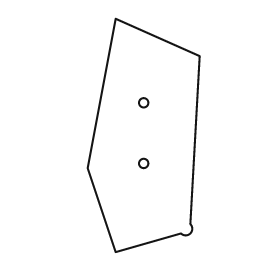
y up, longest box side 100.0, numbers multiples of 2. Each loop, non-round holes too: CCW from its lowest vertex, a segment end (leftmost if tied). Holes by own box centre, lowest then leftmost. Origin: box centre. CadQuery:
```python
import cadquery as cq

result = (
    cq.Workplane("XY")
    .moveTo(-12.0, -50.0)
    .lineTo(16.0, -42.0)
    .threePointArc((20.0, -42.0), (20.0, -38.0))
    .lineTo(24.0, 34.0)
    .lineTo(-12.0, 50.0)
    .lineTo(-24.0, -14.0)
    .close()
    .moveTo(0.0, -12.0)
    .circle(2.0)
    .moveTo(0.0, 14.0)
    .circle(2.0)
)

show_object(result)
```